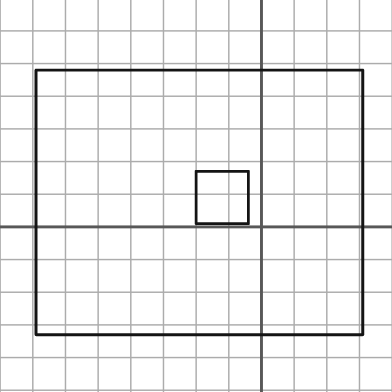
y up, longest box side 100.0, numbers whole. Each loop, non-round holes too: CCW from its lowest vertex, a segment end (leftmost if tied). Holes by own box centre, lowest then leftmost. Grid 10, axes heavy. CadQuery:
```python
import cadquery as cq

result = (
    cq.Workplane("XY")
    .moveTo(-69.0, -33.0)
    .lineTo(31.0, -33.0)
    .lineTo(31.0, 48.0)
    .lineTo(-69.0, 48.0)
    .close()
    .moveTo(-20.0, 1.0)
    .lineTo(-4.0, 1.0)
    .lineTo(-4.0, 17.0)
    .lineTo(-20.0, 17.0)
    .close()
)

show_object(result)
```